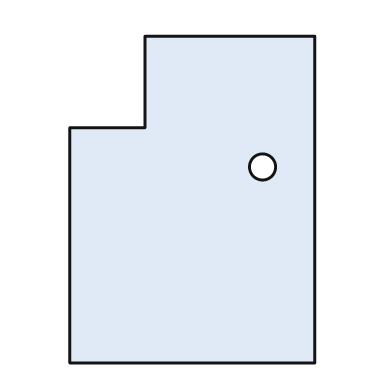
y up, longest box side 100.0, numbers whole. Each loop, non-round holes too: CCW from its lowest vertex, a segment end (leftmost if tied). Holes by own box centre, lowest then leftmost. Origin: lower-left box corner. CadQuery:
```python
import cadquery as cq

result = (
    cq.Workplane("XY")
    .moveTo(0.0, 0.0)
    .lineTo(75.0, 0.0)
    .lineTo(75.0, 100.0)
    .lineTo(23.0, 100.0)
    .lineTo(23.0, 72.0)
    .lineTo(0.0, 72.0)
    .close()
    .moveTo(59.0, 60.0)
    .circle(4.0)
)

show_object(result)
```